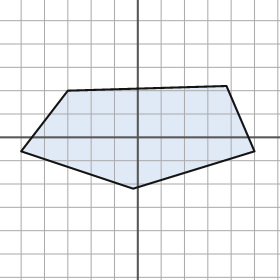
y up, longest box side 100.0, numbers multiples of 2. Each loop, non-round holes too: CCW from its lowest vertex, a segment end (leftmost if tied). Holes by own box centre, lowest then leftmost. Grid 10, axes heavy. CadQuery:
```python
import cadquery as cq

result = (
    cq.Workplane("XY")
    .moveTo(-2.0, -22.0)
    .lineTo(50.0, -6.0)
    .lineTo(38.0, 22.0)
    .lineTo(-30.0, 20.0)
    .lineTo(-50.0, -6.0)
    .close()
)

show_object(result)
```